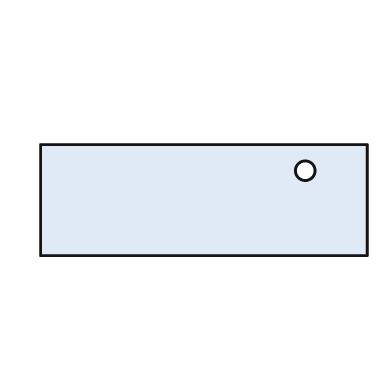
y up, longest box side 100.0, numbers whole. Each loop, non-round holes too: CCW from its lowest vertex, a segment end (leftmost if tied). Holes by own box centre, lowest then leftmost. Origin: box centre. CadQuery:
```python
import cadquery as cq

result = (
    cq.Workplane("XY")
    .moveTo(-50.0, -17.0)
    .lineTo(50.0, -17.0)
    .lineTo(50.0, 17.0)
    .lineTo(-50.0, 17.0)
    .close()
    .moveTo(31.0, 9.0)
    .circle(3.0)
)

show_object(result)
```